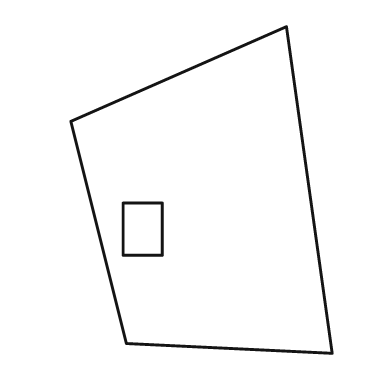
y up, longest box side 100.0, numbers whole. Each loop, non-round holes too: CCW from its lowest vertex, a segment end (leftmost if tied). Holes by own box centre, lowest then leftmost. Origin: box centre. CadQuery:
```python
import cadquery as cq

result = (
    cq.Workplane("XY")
    .moveTo(40.0, -50.0)
    .lineTo(26.0, 50.0)
    .lineTo(-40.0, 21.0)
    .lineTo(-23.0, -47.0)
    .close()
    .moveTo(-24.0, -20.0)
    .lineTo(-12.0, -20.0)
    .lineTo(-12.0, -4.0)
    .lineTo(-24.0, -4.0)
    .close()
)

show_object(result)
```